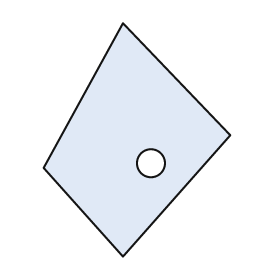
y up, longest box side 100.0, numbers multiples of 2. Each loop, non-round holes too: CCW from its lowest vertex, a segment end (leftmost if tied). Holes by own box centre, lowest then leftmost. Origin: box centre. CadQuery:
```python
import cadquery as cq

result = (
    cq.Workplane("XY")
    .moveTo(-6.0, -50.0)
    .lineTo(40.0, 2.0)
    .lineTo(-6.0, 50.0)
    .lineTo(-40.0, -12.0)
    .close()
    .moveTo(6.0, -10.0)
    .circle(6.0)
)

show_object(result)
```